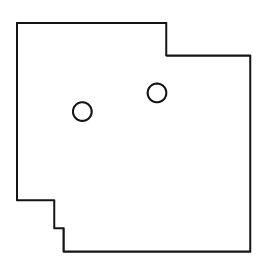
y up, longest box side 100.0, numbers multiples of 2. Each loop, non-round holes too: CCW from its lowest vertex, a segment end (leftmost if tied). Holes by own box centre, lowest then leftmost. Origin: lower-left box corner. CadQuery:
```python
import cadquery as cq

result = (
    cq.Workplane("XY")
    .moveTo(20.0, 0.0)
    .lineTo(100.0, 0.0)
    .lineTo(100.0, 84.0)
    .lineTo(64.0, 84.0)
    .lineTo(64.0, 98.0)
    .lineTo(0.0, 98.0)
    .lineTo(0.0, 22.0)
    .lineTo(16.0, 22.0)
    .lineTo(16.0, 10.0)
    .lineTo(20.0, 10.0)
    .close()
    .moveTo(28.0, 60.0)
    .circle(4.0)
    .moveTo(60.0, 68.0)
    .circle(4.0)
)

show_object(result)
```